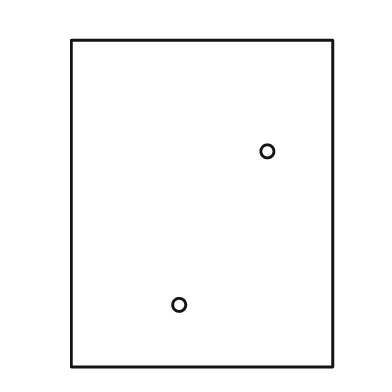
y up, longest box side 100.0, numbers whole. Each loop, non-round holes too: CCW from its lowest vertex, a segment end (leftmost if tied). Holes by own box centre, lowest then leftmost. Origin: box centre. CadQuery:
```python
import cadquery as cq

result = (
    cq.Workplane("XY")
    .moveTo(-40.0, -50.0)
    .lineTo(40.0, -50.0)
    .lineTo(40.0, 50.0)
    .lineTo(-40.0, 50.0)
    .close()
    .moveTo(-7.0, -31.0)
    .circle(2.0)
    .moveTo(20.0, 16.0)
    .circle(2.0)
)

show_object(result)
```